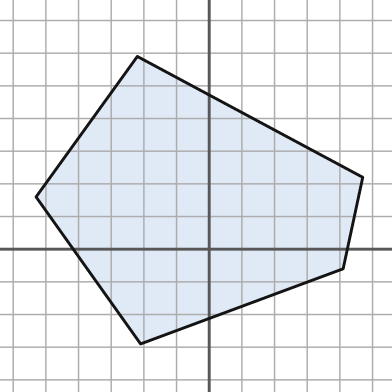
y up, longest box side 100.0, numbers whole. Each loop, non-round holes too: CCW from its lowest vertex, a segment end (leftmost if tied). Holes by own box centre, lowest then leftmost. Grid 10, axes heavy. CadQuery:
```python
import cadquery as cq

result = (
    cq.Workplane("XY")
    .moveTo(-21.0, -29.0)
    .lineTo(41.0, -6.0)
    .lineTo(47.0, 22.0)
    .lineTo(-22.0, 59.0)
    .lineTo(-53.0, 16.0)
    .close()
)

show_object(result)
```